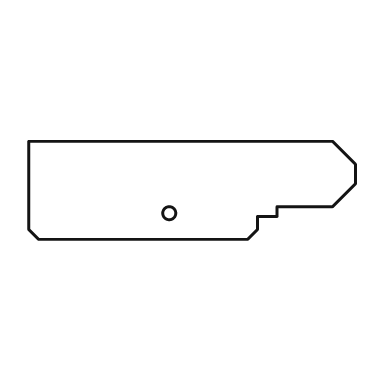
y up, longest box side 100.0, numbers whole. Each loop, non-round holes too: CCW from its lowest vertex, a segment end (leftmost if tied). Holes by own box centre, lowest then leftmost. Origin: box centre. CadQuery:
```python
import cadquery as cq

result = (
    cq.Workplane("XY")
    .moveTo(-47.0, -15.0)
    .lineTo(17.0, -15.0)
    .lineTo(20.0, -12.0)
    .lineTo(20.0, -8.0)
    .lineTo(26.0, -8.0)
    .lineTo(26.0, -5.0)
    .lineTo(43.0, -5.0)
    .lineTo(50.0, 2.0)
    .lineTo(50.0, 8.0)
    .lineTo(43.0, 15.0)
    .lineTo(-50.0, 15.0)
    .lineTo(-50.0, -12.0)
    .close()
    .moveTo(-7.0, -7.0)
    .circle(2.0)
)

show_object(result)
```